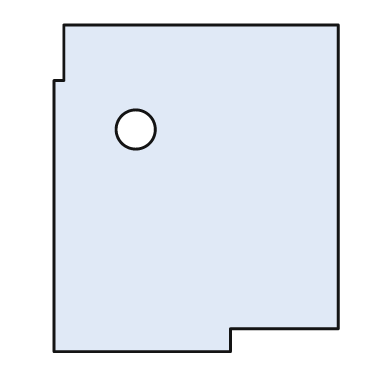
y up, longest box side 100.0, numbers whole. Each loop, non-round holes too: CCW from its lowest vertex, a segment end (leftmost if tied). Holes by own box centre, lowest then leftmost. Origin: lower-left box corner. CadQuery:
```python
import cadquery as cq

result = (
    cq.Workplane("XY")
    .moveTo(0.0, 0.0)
    .lineTo(54.0, 0.0)
    .lineTo(54.0, 7.0)
    .lineTo(87.0, 7.0)
    .lineTo(87.0, 100.0)
    .lineTo(3.0, 100.0)
    .lineTo(3.0, 83.0)
    .lineTo(0.0, 83.0)
    .close()
    .moveTo(25.0, 68.0)
    .circle(6.0)
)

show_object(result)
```